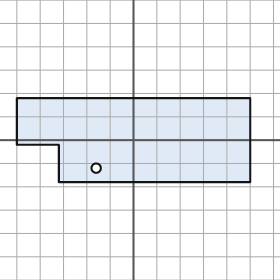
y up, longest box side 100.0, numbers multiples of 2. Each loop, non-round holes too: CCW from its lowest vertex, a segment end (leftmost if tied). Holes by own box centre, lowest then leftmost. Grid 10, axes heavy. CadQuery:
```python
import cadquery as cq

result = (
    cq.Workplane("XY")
    .moveTo(-32.0, -18.0)
    .lineTo(50.0, -18.0)
    .lineTo(50.0, 18.0)
    .lineTo(-50.0, 18.0)
    .lineTo(-50.0, -2.0)
    .lineTo(-32.0, -2.0)
    .close()
    .moveTo(-16.0, -12.0)
    .circle(2.0)
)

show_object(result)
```